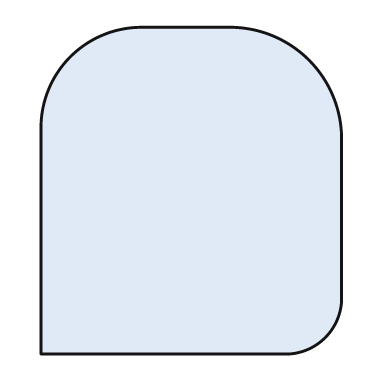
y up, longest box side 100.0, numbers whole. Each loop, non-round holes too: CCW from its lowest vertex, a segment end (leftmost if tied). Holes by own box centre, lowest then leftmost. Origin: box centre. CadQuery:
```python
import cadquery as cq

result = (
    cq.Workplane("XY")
    .moveTo(-46.0, -50.0)
    .lineTo(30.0, -50.0)
    .threePointArc((41.0, -45.0), (46.0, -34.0))
    .lineTo(46.0, 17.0)
    .threePointArc((36.0, 40.0), (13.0, 50.0))
    .lineTo(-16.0, 50.0)
    .threePointArc((-37.0, 41.0), (-46.0, 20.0))
    .close()
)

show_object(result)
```